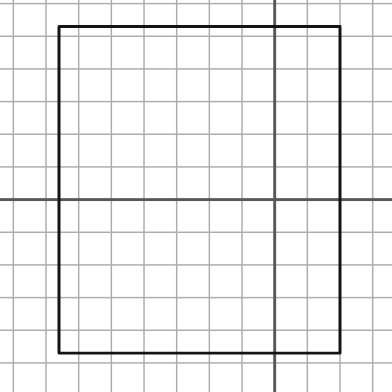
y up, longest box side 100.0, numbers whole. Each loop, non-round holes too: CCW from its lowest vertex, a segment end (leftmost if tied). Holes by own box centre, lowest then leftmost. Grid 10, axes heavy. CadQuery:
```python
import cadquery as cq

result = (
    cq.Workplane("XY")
    .moveTo(-66.0, -47.0)
    .lineTo(20.0, -47.0)
    .lineTo(20.0, 53.0)
    .lineTo(-66.0, 53.0)
    .close()
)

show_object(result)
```